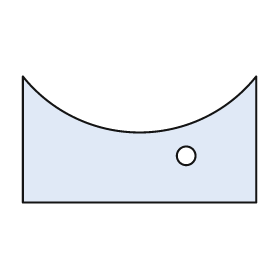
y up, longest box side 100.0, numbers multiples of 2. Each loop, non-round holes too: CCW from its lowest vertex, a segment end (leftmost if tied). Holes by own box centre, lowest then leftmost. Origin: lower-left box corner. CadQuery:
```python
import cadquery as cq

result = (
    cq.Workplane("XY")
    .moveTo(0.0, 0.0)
    .lineTo(100.0, 0.0)
    .lineTo(100.0, 54.0)
    .threePointArc((50.0, 30.0), (0.0, 54.0))
    .close()
    .moveTo(70.0, 20.0)
    .circle(4.0)
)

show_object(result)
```